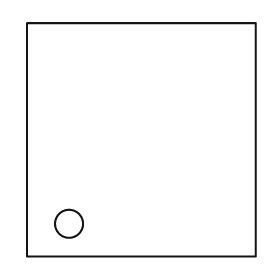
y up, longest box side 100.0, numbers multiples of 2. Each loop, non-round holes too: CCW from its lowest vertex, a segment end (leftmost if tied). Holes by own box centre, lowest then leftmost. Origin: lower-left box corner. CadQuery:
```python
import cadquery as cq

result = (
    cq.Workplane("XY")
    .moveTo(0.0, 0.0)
    .lineTo(98.0, 0.0)
    .lineTo(98.0, 100.0)
    .lineTo(0.0, 100.0)
    .close()
    .moveTo(18.0, 14.0)
    .circle(6.0)
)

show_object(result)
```